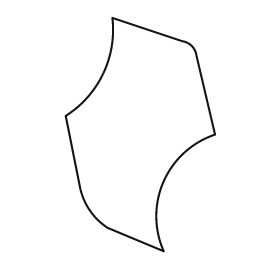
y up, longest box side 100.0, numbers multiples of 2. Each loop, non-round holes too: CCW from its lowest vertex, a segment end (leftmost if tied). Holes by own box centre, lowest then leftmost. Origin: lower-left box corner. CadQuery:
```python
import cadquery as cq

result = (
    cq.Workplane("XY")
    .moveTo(42.0, 0.0)
    .threePointArc((42.0, 30.0), (64.0, 50.0))
    .lineTo(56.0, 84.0)
    .threePointArc((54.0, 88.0), (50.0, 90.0))
    .lineTo(20.0, 100.0)
    .threePointArc((16.0, 76.0), (0.0, 58.0))
    .lineTo(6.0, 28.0)
    .threePointArc((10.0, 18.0), (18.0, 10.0))
    .close()
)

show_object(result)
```